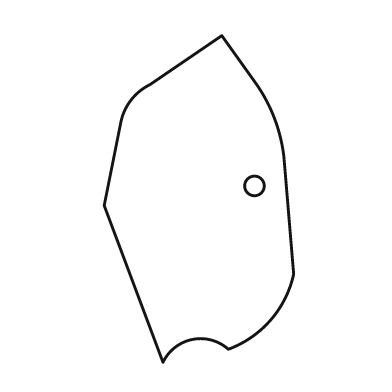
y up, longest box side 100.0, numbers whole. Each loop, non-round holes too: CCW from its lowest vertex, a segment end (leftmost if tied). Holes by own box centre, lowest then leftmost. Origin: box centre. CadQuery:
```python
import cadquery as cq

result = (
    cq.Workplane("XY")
    .moveTo(-11.0, -50.0)
    .threePointArc((-2.0, -43.0), (9.0, -46.0))
    .threePointArc((22.0, -37.0), (29.0, -23.0))
    .lineTo(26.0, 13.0)
    .threePointArc((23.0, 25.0), (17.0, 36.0))
    .lineTo(7.0, 50.0)
    .lineTo(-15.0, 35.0)
    .threePointArc((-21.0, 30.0), (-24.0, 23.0))
    .lineTo(-29.0, -2.0)
    .close()
    .moveTo(17.0, 4.0)
    .circle(3.0)
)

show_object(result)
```